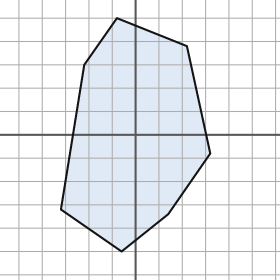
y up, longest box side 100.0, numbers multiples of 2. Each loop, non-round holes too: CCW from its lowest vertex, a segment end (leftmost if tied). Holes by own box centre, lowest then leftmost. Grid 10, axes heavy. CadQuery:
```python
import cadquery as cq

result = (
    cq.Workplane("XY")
    .moveTo(-6.0, -50.0)
    .lineTo(14.0, -34.0)
    .lineTo(32.0, -8.0)
    .lineTo(22.0, 38.0)
    .lineTo(-8.0, 50.0)
    .lineTo(-22.0, 30.0)
    .lineTo(-32.0, -32.0)
    .close()
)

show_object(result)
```